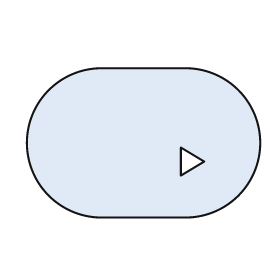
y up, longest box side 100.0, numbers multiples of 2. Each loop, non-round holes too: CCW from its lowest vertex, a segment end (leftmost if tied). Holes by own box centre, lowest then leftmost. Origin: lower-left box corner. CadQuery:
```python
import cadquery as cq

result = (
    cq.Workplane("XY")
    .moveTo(32.0, 0.0)
    .lineTo(68.0, 0.0)
    .threePointArc((100.0, 32.0), (68.0, 64.0))
    .lineTo(32.0, 64.0)
    .threePointArc((0.0, 32.0), (32.0, 0.0))
    .close()
    .moveTo(66.0, 18.0)
    .lineTo(76.0, 24.0)
    .lineTo(66.0, 30.0)
    .close()
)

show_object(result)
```